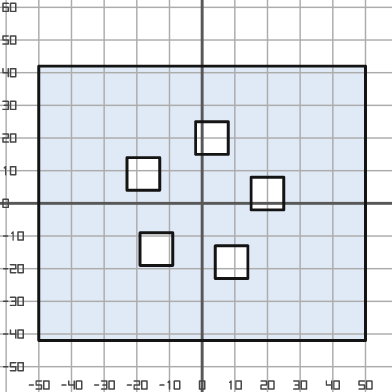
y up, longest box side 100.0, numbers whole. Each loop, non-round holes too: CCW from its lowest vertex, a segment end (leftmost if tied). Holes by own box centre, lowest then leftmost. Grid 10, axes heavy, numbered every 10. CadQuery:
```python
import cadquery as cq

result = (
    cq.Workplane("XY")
    .moveTo(-50.0, -42.0)
    .lineTo(50.0, -42.0)
    .lineTo(50.0, 42.0)
    .lineTo(-50.0, 42.0)
    .close()
    .moveTo(4.0, -23.0)
    .lineTo(14.0, -23.0)
    .lineTo(14.0, -13.0)
    .lineTo(4.0, -13.0)
    .close()
    .moveTo(-19.0, -19.0)
    .lineTo(-9.0, -19.0)
    .lineTo(-9.0, -9.0)
    .lineTo(-19.0, -9.0)
    .close()
    .moveTo(15.0, -2.0)
    .lineTo(25.0, -2.0)
    .lineTo(25.0, 8.0)
    .lineTo(15.0, 8.0)
    .close()
    .moveTo(-23.0, 4.0)
    .lineTo(-13.0, 4.0)
    .lineTo(-13.0, 14.0)
    .lineTo(-23.0, 14.0)
    .close()
    .moveTo(-2.0, 15.0)
    .lineTo(8.0, 15.0)
    .lineTo(8.0, 25.0)
    .lineTo(-2.0, 25.0)
    .close()
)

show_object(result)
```